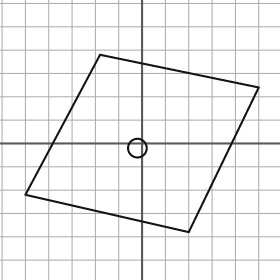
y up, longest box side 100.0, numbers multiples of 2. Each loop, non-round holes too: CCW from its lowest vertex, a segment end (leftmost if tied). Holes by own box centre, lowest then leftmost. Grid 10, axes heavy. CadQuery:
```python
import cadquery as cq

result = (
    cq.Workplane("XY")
    .moveTo(20.0, -38.0)
    .lineTo(50.0, 24.0)
    .lineTo(-18.0, 38.0)
    .lineTo(-50.0, -22.0)
    .close()
    .moveTo(-2.0, -2.0)
    .circle(4.0)
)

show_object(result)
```